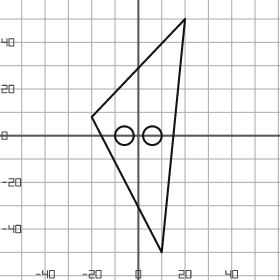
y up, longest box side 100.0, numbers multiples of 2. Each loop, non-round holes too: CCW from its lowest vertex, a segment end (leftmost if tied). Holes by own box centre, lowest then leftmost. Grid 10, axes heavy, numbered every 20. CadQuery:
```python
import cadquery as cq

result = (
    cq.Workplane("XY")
    .moveTo(10.0, -50.0)
    .lineTo(20.0, 50.0)
    .lineTo(-20.0, 8.0)
    .close()
    .moveTo(-6.0, 0.0)
    .circle(4.0)
    .moveTo(6.0, 0.0)
    .circle(4.0)
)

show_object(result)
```